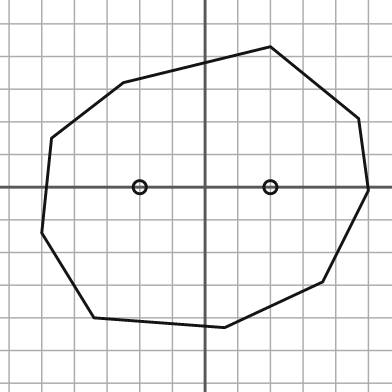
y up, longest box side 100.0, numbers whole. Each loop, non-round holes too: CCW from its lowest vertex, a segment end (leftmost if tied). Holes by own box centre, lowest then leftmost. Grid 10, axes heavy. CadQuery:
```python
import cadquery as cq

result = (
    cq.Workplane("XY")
    .moveTo(6.0, -43.0)
    .lineTo(36.0, -29.0)
    .lineTo(50.0, -1.0)
    .lineTo(47.0, 21.0)
    .lineTo(20.0, 43.0)
    .lineTo(-25.0, 32.0)
    .lineTo(-47.0, 15.0)
    .lineTo(-50.0, -14.0)
    .lineTo(-34.0, -40.0)
    .close()
    .moveTo(-20.0, 0.0)
    .circle(2.0)
    .moveTo(20.0, 0.0)
    .circle(2.0)
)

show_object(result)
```